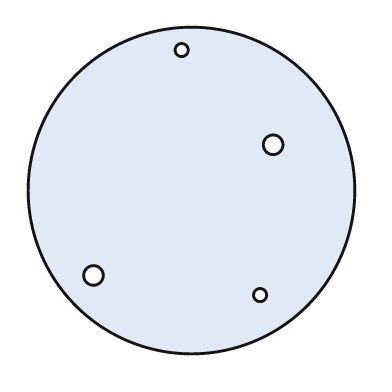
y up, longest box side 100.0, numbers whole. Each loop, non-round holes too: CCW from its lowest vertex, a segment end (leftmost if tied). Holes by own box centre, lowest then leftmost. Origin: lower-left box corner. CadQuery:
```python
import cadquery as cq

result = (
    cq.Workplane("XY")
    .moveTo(50.0, 50.0)
    .circle(50.0)
    .moveTo(71.0, 18.0)
    .circle(2.0)
    .moveTo(20.0, 24.0)
    .circle(3.0)
    .moveTo(75.0, 64.0)
    .circle(3.0)
    .moveTo(47.0, 93.0)
    .circle(2.0)
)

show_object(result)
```